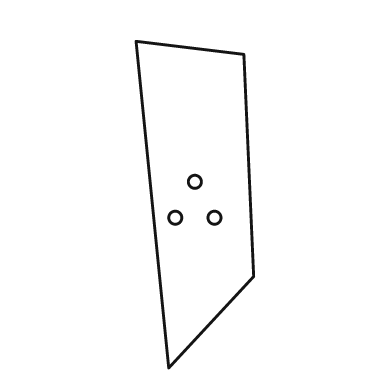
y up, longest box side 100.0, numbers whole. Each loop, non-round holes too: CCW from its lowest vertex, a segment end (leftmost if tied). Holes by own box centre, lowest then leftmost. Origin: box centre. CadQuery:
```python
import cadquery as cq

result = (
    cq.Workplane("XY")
    .moveTo(-8.0, -50.0)
    .lineTo(18.0, -22.0)
    .lineTo(15.0, 46.0)
    .lineTo(-18.0, 50.0)
    .close()
    .moveTo(-6.0, -4.0)
    .circle(2.0)
    .moveTo(6.0, -4.0)
    .circle(2.0)
    .moveTo(0.0, 7.0)
    .circle(2.0)
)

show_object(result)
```